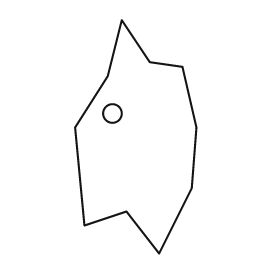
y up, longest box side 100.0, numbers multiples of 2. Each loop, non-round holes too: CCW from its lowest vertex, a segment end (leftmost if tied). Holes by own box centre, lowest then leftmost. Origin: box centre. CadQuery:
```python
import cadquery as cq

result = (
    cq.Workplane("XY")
    .moveTo(10.0, -50.0)
    .lineTo(24.0, -22.0)
    .lineTo(26.0, 4.0)
    .lineTo(20.0, 30.0)
    .lineTo(6.0, 32.0)
    .lineTo(-6.0, 50.0)
    .lineTo(-12.0, 26.0)
    .lineTo(-26.0, 4.0)
    .lineTo(-22.0, -38.0)
    .lineTo(-4.0, -32.0)
    .close()
    .moveTo(-10.0, 10.0)
    .circle(4.0)
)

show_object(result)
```